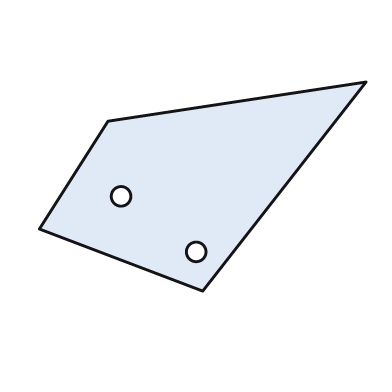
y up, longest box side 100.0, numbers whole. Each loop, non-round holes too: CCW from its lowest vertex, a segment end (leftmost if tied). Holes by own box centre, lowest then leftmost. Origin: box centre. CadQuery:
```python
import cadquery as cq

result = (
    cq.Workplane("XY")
    .moveTo(0.0, -32.0)
    .lineTo(50.0, 32.0)
    .lineTo(-29.0, 20.0)
    .lineTo(-50.0, -13.0)
    .close()
    .moveTo(-2.0, -20.0)
    .circle(3.0)
    .moveTo(-25.0, -3.0)
    .circle(3.0)
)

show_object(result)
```